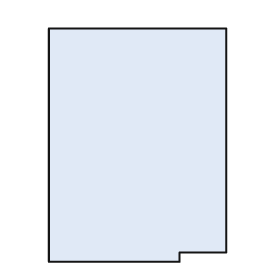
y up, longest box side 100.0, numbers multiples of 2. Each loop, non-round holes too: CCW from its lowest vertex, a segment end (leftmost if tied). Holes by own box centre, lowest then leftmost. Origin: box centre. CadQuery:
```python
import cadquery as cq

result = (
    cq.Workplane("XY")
    .moveTo(-38.0, -50.0)
    .lineTo(18.0, -50.0)
    .lineTo(18.0, -46.0)
    .lineTo(38.0, -46.0)
    .lineTo(38.0, 50.0)
    .lineTo(-38.0, 50.0)
    .close()
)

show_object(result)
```